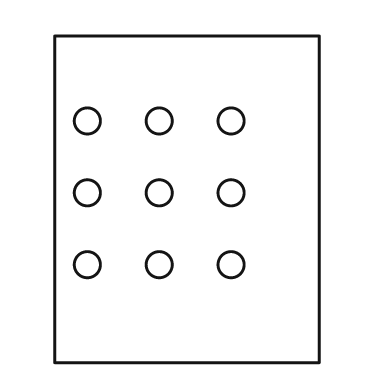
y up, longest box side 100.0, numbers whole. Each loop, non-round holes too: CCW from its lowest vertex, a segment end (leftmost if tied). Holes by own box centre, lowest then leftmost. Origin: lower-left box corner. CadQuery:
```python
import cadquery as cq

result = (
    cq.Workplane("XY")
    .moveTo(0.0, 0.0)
    .lineTo(81.0, 0.0)
    .lineTo(81.0, 100.0)
    .lineTo(0.0, 100.0)
    .close()
    .moveTo(10.0, 30.0)
    .circle(4.0)
    .moveTo(32.0, 30.0)
    .circle(4.0)
    .moveTo(54.0, 30.0)
    .circle(4.0)
    .moveTo(10.0, 52.0)
    .circle(4.0)
    .moveTo(32.0, 52.0)
    .circle(4.0)
    .moveTo(54.0, 52.0)
    .circle(4.0)
    .moveTo(10.0, 74.0)
    .circle(4.0)
    .moveTo(32.0, 74.0)
    .circle(4.0)
    .moveTo(54.0, 74.0)
    .circle(4.0)
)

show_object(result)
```